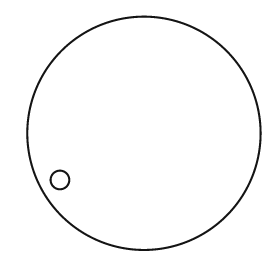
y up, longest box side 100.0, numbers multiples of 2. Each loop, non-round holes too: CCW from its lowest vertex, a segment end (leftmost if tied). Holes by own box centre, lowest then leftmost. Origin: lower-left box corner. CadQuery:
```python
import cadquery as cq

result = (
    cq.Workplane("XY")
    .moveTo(50.0, 50.0)
    .circle(50.0)
    .moveTo(14.0, 30.0)
    .circle(4.0)
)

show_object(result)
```